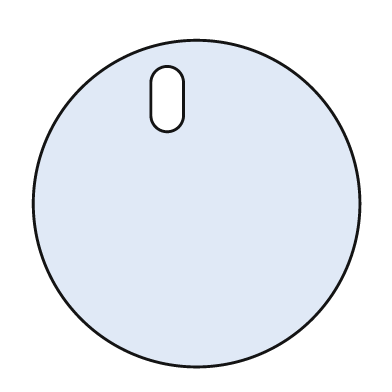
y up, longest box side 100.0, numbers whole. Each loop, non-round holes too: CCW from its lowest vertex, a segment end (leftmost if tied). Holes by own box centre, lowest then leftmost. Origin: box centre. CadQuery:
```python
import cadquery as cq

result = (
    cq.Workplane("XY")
    .moveTo(0.0, 0.0)
    .circle(50.0)
    .moveTo(-14.0, 27.0)
    .threePointArc((-9.0, 22.0), (-4.0, 27.0))
    .lineTo(-4.0, 37.0)
    .threePointArc((-9.0, 42.0), (-14.0, 37.0))
    .close()
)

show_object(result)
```